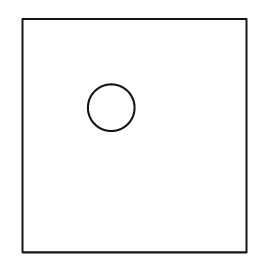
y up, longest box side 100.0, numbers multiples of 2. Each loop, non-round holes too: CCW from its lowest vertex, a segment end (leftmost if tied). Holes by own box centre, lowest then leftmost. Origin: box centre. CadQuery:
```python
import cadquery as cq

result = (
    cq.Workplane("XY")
    .moveTo(-48.0, -50.0)
    .lineTo(48.0, -50.0)
    .lineTo(48.0, 50.0)
    .lineTo(-48.0, 50.0)
    .close()
    .moveTo(-10.0, 12.0)
    .circle(10.0)
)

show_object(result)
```